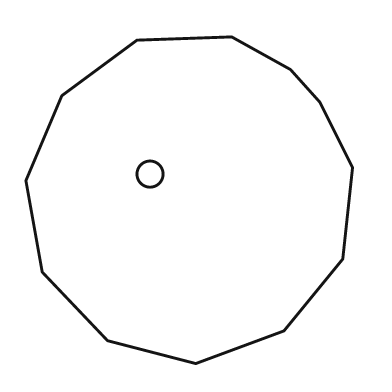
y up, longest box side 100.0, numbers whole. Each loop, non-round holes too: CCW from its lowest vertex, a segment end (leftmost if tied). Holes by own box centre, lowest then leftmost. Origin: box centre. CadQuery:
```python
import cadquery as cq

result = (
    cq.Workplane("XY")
    .moveTo(2.0, -50.0)
    .lineTo(29.0, -40.0)
    .lineTo(47.0, -18.0)
    .lineTo(50.0, 10.0)
    .lineTo(40.0, 30.0)
    .lineTo(31.0, 40.0)
    .lineTo(13.0, 50.0)
    .lineTo(-16.0, 49.0)
    .lineTo(-39.0, 32.0)
    .lineTo(-50.0, 6.0)
    .lineTo(-45.0, -22.0)
    .lineTo(-25.0, -43.0)
    .close()
    .moveTo(-12.0, 8.0)
    .circle(4.0)
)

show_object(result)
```